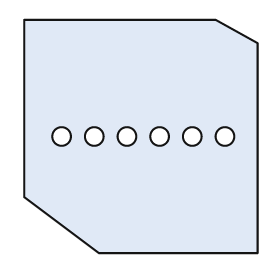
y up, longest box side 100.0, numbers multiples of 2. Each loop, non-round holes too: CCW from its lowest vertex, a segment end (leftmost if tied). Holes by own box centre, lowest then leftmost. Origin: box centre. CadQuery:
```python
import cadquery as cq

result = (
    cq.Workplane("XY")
    .moveTo(-18.0, -50.0)
    .lineTo(50.0, -50.0)
    .lineTo(50.0, 40.0)
    .lineTo(32.0, 50.0)
    .lineTo(-50.0, 50.0)
    .lineTo(-50.0, -26.0)
    .close()
    .moveTo(-34.0, 0.0)
    .circle(4.0)
    .moveTo(-20.0, 0.0)
    .circle(4.0)
    .moveTo(-6.0, 0.0)
    .circle(4.0)
    .moveTo(8.0, 0.0)
    .circle(4.0)
    .moveTo(22.0, 0.0)
    .circle(4.0)
    .moveTo(36.0, 0.0)
    .circle(4.0)
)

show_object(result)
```